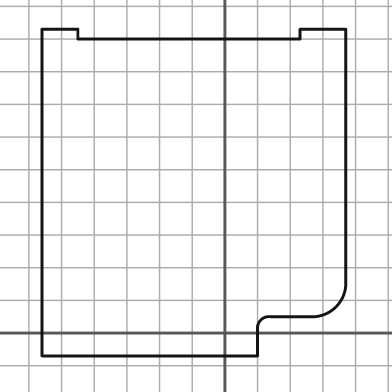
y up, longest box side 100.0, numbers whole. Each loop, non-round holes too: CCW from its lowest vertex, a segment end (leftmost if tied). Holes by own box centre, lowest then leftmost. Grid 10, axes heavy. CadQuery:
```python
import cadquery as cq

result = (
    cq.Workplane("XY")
    .moveTo(-56.0, -7.0)
    .lineTo(10.0, -7.0)
    .lineTo(10.0, 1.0)
    .threePointArc((11.0, 4.0), (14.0, 5.0))
    .lineTo(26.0, 5.0)
    .threePointArc((34.0, 8.0), (37.0, 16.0))
    .lineTo(37.0, 93.0)
    .lineTo(23.0, 93.0)
    .lineTo(23.0, 90.0)
    .lineTo(-45.0, 90.0)
    .lineTo(-45.0, 93.0)
    .lineTo(-56.0, 93.0)
    .close()
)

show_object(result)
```